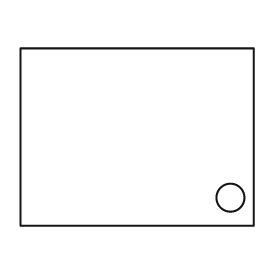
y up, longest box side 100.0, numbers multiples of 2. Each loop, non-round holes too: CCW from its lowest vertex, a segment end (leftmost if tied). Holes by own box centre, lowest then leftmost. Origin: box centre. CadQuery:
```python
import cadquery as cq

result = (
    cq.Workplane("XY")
    .moveTo(-50.0, -38.0)
    .lineTo(50.0, -38.0)
    .lineTo(50.0, 38.0)
    .lineTo(-50.0, 38.0)
    .close()
    .moveTo(40.0, -26.0)
    .circle(6.0)
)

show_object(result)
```